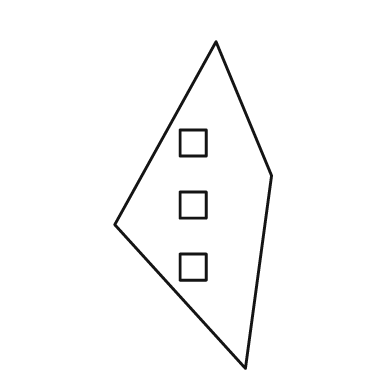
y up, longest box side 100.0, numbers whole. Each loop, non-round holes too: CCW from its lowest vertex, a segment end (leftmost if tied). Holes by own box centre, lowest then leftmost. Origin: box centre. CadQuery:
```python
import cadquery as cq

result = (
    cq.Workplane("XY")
    .moveTo(16.0, -50.0)
    .lineTo(24.0, 9.0)
    .lineTo(7.0, 50.0)
    .lineTo(-24.0, -6.0)
    .close()
    .moveTo(-4.0, -23.0)
    .lineTo(4.0, -23.0)
    .lineTo(4.0, -15.0)
    .lineTo(-4.0, -15.0)
    .close()
    .moveTo(-4.0, -4.0)
    .lineTo(4.0, -4.0)
    .lineTo(4.0, 4.0)
    .lineTo(-4.0, 4.0)
    .close()
    .moveTo(-4.0, 15.0)
    .lineTo(4.0, 15.0)
    .lineTo(4.0, 23.0)
    .lineTo(-4.0, 23.0)
    .close()
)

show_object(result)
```